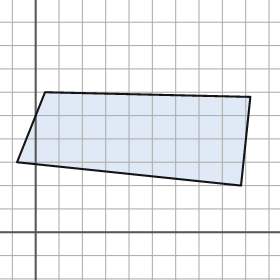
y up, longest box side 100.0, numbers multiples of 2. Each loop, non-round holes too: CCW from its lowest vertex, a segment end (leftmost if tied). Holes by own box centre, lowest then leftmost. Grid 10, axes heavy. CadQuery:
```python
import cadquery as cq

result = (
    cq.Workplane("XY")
    .moveTo(88.0, 20.0)
    .lineTo(92.0, 58.0)
    .lineTo(4.0, 60.0)
    .lineTo(-8.0, 30.0)
    .close()
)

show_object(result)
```